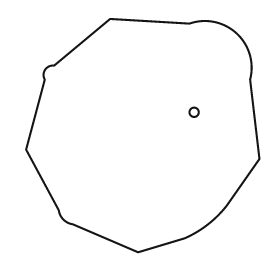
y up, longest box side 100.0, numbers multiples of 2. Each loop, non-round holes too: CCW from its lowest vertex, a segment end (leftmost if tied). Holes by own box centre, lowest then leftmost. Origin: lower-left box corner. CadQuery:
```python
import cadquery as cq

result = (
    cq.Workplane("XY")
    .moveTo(48.0, 0.0)
    .lineTo(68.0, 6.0)
    .threePointArc((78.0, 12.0), (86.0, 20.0))
    .lineTo(100.0, 40.0)
    .lineTo(96.0, 74.0)
    .threePointArc((90.0, 94.0), (70.0, 98.0))
    .lineTo(36.0, 100.0)
    .lineTo(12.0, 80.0)
    .threePointArc((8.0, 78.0), (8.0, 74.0))
    .lineTo(0.0, 44.0)
    .lineTo(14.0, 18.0)
    .threePointArc((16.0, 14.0), (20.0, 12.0))
    .close()
    .moveTo(72.0, 60.0)
    .circle(2.0)
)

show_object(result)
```